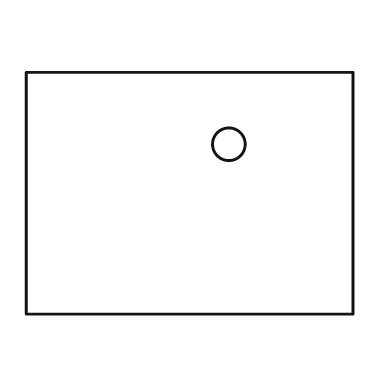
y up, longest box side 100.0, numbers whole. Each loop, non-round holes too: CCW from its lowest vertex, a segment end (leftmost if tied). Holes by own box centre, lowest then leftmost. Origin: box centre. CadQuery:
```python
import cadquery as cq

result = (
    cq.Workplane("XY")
    .moveTo(-50.0, -37.0)
    .lineTo(50.0, -37.0)
    .lineTo(50.0, 37.0)
    .lineTo(-50.0, 37.0)
    .close()
    .moveTo(12.0, 15.0)
    .circle(5.0)
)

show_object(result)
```